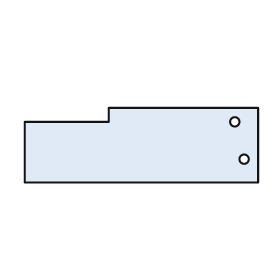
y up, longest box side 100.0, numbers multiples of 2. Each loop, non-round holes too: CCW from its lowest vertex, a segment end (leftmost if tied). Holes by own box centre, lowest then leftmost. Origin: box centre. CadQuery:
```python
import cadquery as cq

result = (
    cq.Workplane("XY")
    .moveTo(-50.0, -16.0)
    .lineTo(50.0, -16.0)
    .lineTo(50.0, 16.0)
    .lineTo(-14.0, 16.0)
    .lineTo(-14.0, 10.0)
    .lineTo(-50.0, 10.0)
    .close()
    .moveTo(44.0, -6.0)
    .circle(2.0)
    .moveTo(40.0, 10.0)
    .circle(2.0)
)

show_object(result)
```